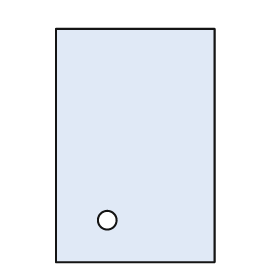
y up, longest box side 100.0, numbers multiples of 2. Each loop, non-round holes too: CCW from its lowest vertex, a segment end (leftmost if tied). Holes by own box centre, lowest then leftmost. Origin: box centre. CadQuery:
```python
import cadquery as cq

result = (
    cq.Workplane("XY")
    .moveTo(-34.0, -50.0)
    .lineTo(34.0, -50.0)
    .lineTo(34.0, 50.0)
    .lineTo(-34.0, 50.0)
    .close()
    .moveTo(-12.0, -32.0)
    .circle(4.0)
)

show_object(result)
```